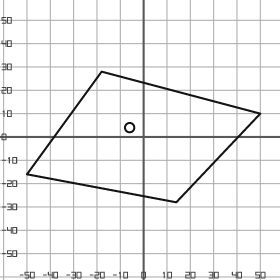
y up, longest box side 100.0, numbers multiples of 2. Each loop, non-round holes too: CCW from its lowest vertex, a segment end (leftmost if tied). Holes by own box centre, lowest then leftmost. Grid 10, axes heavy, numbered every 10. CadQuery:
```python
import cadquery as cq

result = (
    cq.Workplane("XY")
    .moveTo(14.0, -28.0)
    .lineTo(50.0, 10.0)
    .lineTo(-18.0, 28.0)
    .lineTo(-50.0, -16.0)
    .close()
    .moveTo(-6.0, 4.0)
    .circle(2.0)
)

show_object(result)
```